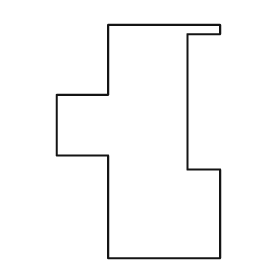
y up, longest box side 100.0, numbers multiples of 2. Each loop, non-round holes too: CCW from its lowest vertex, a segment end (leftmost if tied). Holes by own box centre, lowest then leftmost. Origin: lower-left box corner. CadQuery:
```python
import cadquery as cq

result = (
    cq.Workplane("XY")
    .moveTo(22.0, 0.0)
    .lineTo(70.0, 0.0)
    .lineTo(70.0, 38.0)
    .lineTo(56.0, 38.0)
    .lineTo(56.0, 96.0)
    .lineTo(70.0, 96.0)
    .lineTo(70.0, 100.0)
    .lineTo(22.0, 100.0)
    .lineTo(22.0, 70.0)
    .lineTo(0.0, 70.0)
    .lineTo(0.0, 44.0)
    .lineTo(22.0, 44.0)
    .close()
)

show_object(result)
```